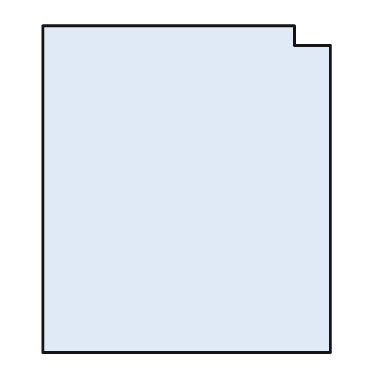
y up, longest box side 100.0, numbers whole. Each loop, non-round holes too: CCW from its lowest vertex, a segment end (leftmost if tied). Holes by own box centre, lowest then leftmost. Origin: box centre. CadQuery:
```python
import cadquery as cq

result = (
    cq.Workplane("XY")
    .moveTo(-44.0, -50.0)
    .lineTo(44.0, -50.0)
    .lineTo(44.0, 44.0)
    .lineTo(33.0, 44.0)
    .lineTo(33.0, 50.0)
    .lineTo(-44.0, 50.0)
    .close()
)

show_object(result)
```